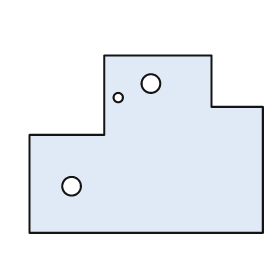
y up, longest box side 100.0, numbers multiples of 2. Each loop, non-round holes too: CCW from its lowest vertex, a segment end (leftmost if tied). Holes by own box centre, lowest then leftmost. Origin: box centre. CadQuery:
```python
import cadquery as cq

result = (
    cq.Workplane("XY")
    .moveTo(-50.0, -38.0)
    .lineTo(50.0, -38.0)
    .lineTo(50.0, 16.0)
    .lineTo(28.0, 16.0)
    .lineTo(28.0, 38.0)
    .lineTo(-18.0, 38.0)
    .lineTo(-18.0, 4.0)
    .lineTo(-50.0, 4.0)
    .close()
    .moveTo(-32.0, -18.0)
    .circle(4.0)
    .moveTo(-12.0, 20.0)
    .circle(2.0)
    .moveTo(2.0, 26.0)
    .circle(4.0)
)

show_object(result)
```